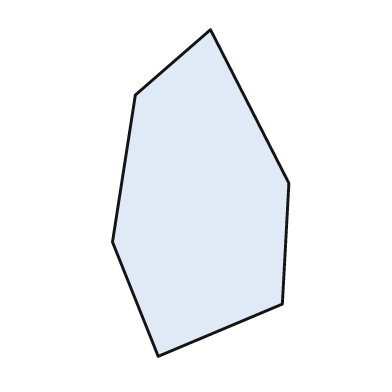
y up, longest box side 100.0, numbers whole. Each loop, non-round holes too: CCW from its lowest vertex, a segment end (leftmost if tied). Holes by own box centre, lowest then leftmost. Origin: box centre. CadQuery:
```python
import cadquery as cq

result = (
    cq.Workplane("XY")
    .moveTo(-13.0, -50.0)
    .lineTo(25.0, -34.0)
    .lineTo(27.0, 3.0)
    .lineTo(3.0, 50.0)
    .lineTo(-20.0, 30.0)
    .lineTo(-27.0, -15.0)
    .close()
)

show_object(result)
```